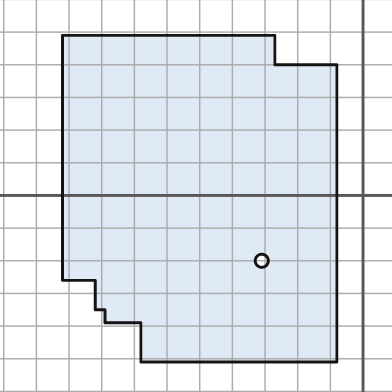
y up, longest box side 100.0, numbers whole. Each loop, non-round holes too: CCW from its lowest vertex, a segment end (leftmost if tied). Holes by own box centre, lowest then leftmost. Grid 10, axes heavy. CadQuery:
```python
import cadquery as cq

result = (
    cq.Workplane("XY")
    .moveTo(-68.0, -51.0)
    .lineTo(-8.0, -51.0)
    .lineTo(-8.0, 40.0)
    .lineTo(-27.0, 40.0)
    .lineTo(-27.0, 49.0)
    .lineTo(-92.0, 49.0)
    .lineTo(-92.0, -26.0)
    .lineTo(-82.0, -26.0)
    .lineTo(-82.0, -35.0)
    .lineTo(-79.0, -35.0)
    .lineTo(-79.0, -39.0)
    .lineTo(-68.0, -39.0)
    .close()
    .moveTo(-31.0, -20.0)
    .circle(2.0)
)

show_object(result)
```